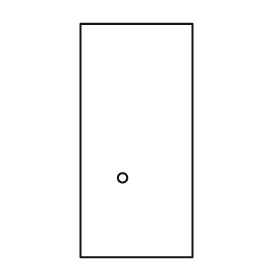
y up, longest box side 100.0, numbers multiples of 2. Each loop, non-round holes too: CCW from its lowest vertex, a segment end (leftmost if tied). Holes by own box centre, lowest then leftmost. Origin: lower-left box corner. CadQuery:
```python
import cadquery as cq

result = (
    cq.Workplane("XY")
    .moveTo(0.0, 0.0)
    .lineTo(48.0, 0.0)
    .lineTo(48.0, 100.0)
    .lineTo(0.0, 100.0)
    .close()
    .moveTo(18.0, 34.0)
    .circle(2.0)
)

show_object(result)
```